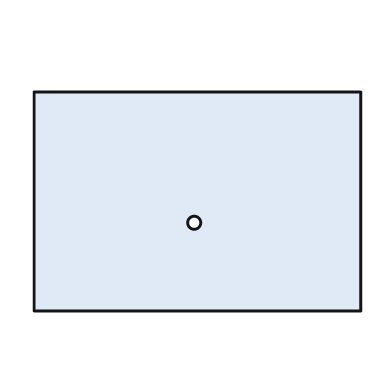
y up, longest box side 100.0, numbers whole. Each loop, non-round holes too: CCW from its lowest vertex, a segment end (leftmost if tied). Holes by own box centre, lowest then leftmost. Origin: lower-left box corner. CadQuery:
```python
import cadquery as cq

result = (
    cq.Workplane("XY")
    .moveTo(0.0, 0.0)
    .lineTo(100.0, 0.0)
    .lineTo(100.0, 67.0)
    .lineTo(0.0, 67.0)
    .close()
    .moveTo(49.0, 27.0)
    .circle(2.0)
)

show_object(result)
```